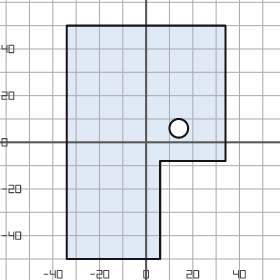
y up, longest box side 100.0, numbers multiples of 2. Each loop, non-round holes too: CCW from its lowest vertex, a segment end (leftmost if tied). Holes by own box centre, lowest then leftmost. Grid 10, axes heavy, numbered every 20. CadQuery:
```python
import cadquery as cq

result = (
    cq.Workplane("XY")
    .moveTo(-34.0, -50.0)
    .lineTo(6.0, -50.0)
    .lineTo(6.0, -8.0)
    .lineTo(34.0, -8.0)
    .lineTo(34.0, 50.0)
    .lineTo(-34.0, 50.0)
    .close()
    .moveTo(14.0, 6.0)
    .circle(4.0)
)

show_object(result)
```